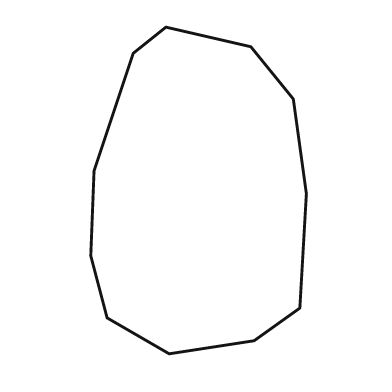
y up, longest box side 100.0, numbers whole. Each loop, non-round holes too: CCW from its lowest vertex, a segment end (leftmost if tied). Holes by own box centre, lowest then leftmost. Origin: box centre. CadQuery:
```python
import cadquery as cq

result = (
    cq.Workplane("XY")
    .moveTo(-9.0, -50.0)
    .lineTo(17.0, -46.0)
    .lineTo(31.0, -36.0)
    .lineTo(33.0, -1.0)
    .lineTo(29.0, 28.0)
    .lineTo(16.0, 44.0)
    .lineTo(-10.0, 50.0)
    .lineTo(-20.0, 42.0)
    .lineTo(-32.0, 6.0)
    .lineTo(-33.0, -20.0)
    .lineTo(-28.0, -39.0)
    .close()
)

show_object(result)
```